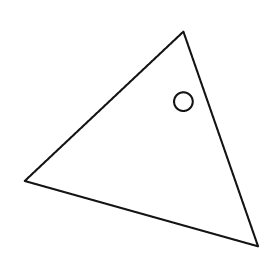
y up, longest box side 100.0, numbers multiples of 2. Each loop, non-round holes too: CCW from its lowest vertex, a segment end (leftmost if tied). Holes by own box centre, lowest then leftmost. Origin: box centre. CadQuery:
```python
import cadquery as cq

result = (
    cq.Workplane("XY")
    .moveTo(50.0, -46.0)
    .lineTo(18.0, 46.0)
    .lineTo(-50.0, -18.0)
    .close()
    .moveTo(18.0, 16.0)
    .circle(4.0)
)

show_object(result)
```